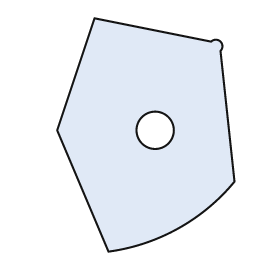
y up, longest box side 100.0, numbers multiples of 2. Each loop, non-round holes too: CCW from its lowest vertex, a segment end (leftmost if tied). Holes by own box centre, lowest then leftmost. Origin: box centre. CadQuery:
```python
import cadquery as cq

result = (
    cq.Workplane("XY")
    .moveTo(-16.0, -50.0)
    .threePointArc((14.0, -40.0), (38.0, -20.0))
    .lineTo(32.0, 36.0)
    .threePointArc((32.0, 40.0), (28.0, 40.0))
    .lineTo(-22.0, 50.0)
    .lineTo(-38.0, 2.0)
    .close()
    .moveTo(4.0, 2.0)
    .circle(8.0)
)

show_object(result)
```